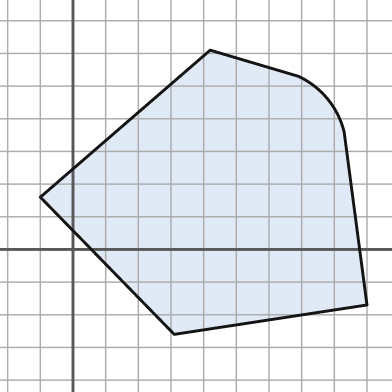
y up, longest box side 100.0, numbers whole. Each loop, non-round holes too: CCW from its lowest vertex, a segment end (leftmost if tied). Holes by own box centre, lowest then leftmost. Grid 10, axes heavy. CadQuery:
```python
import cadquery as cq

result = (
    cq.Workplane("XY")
    .moveTo(31.0, -26.0)
    .lineTo(90.0, -17.0)
    .lineTo(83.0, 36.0)
    .threePointArc((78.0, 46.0), (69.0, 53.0))
    .lineTo(42.0, 61.0)
    .lineTo(-10.0, 16.0)
    .close()
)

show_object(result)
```